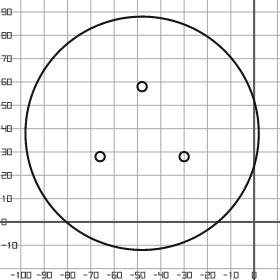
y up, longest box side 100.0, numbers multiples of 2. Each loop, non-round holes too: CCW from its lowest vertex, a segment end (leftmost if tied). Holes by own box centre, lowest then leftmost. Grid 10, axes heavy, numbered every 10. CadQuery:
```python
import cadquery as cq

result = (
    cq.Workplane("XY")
    .moveTo(-48.0, 38.0)
    .circle(50.0)
    .moveTo(-66.0, 28.0)
    .circle(2.0)
    .moveTo(-30.0, 28.0)
    .circle(2.0)
    .moveTo(-48.0, 58.0)
    .circle(2.0)
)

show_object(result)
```